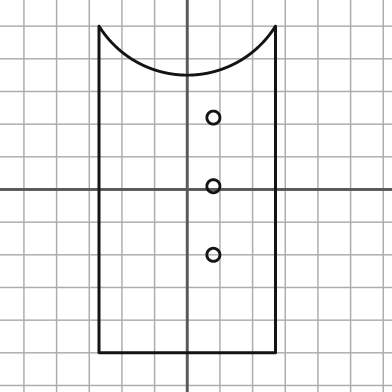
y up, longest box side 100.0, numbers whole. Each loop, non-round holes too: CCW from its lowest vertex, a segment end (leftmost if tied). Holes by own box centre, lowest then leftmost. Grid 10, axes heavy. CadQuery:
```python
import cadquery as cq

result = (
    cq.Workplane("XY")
    .moveTo(-27.0, -50.0)
    .lineTo(27.0, -50.0)
    .lineTo(27.0, 50.0)
    .threePointArc((0.0, 35.0), (-27.0, 50.0))
    .close()
    .moveTo(8.0, -20.0)
    .circle(2.0)
    .moveTo(8.0, 1.0)
    .circle(2.0)
    .moveTo(8.0, 22.0)
    .circle(2.0)
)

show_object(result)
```